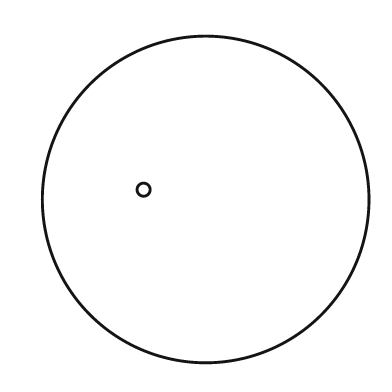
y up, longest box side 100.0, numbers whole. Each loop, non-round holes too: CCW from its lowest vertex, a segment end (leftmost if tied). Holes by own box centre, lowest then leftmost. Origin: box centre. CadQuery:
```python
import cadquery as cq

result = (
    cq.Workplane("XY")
    .moveTo(0.0, 0.0)
    .circle(50.0)
    .moveTo(-19.0, 3.0)
    .circle(2.0)
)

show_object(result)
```